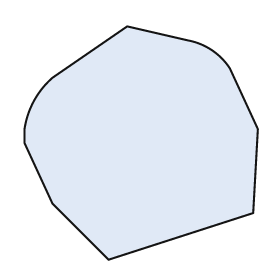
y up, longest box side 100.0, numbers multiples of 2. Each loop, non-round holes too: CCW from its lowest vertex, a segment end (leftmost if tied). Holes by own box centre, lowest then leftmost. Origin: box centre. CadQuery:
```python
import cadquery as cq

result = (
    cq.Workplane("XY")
    .moveTo(-14.0, -50.0)
    .lineTo(48.0, -30.0)
    .lineTo(50.0, 6.0)
    .lineTo(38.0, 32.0)
    .threePointArc((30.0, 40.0), (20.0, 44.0))
    .lineTo(-6.0, 50.0)
    .lineTo(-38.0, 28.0)
    .threePointArc((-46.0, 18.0), (-50.0, 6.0))
    .lineTo(-50.0, 0.0)
    .lineTo(-38.0, -26.0)
    .close()
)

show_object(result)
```